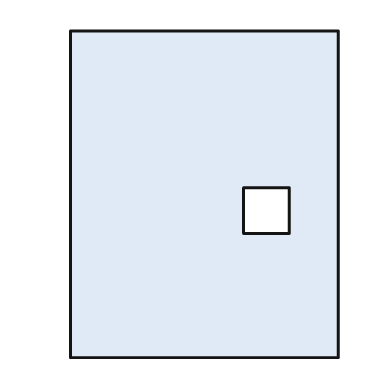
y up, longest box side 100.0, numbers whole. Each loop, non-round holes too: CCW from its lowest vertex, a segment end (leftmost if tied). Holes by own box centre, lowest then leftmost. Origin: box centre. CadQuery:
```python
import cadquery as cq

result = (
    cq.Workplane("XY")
    .moveTo(-41.0, -50.0)
    .lineTo(41.0, -50.0)
    .lineTo(41.0, 50.0)
    .lineTo(-41.0, 50.0)
    .close()
    .moveTo(12.0, -12.0)
    .lineTo(26.0, -12.0)
    .lineTo(26.0, 2.0)
    .lineTo(12.0, 2.0)
    .close()
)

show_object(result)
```